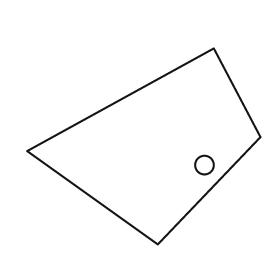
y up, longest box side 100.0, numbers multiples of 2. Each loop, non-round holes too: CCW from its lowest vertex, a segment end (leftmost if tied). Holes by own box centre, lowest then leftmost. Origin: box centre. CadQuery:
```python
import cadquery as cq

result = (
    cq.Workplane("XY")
    .moveTo(6.0, -42.0)
    .lineTo(50.0, 4.0)
    .lineTo(30.0, 42.0)
    .lineTo(-50.0, -2.0)
    .close()
    .moveTo(26.0, -8.0)
    .circle(4.0)
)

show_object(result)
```